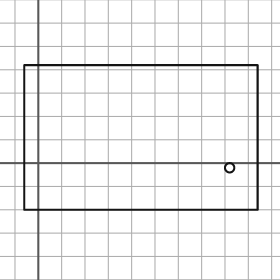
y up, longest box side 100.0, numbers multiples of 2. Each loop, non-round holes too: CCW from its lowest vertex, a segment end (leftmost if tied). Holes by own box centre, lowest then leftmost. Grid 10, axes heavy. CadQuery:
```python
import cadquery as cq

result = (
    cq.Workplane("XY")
    .moveTo(-6.0, -20.0)
    .lineTo(94.0, -20.0)
    .lineTo(94.0, 42.0)
    .lineTo(-6.0, 42.0)
    .close()
    .moveTo(82.0, -2.0)
    .circle(2.0)
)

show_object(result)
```